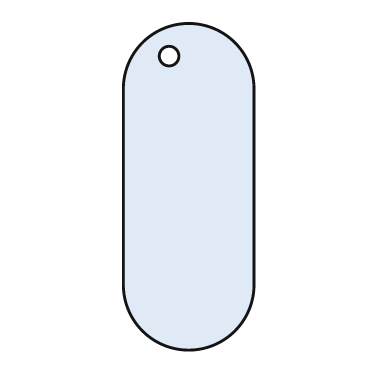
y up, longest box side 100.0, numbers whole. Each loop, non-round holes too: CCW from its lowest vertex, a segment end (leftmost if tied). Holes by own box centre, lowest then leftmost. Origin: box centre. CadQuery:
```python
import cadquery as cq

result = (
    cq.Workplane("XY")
    .moveTo(-20.0, -30.0)
    .threePointArc((0.0, -50.0), (20.0, -30.0))
    .lineTo(20.0, 30.0)
    .threePointArc((0.0, 50.0), (-20.0, 30.0))
    .close()
    .moveTo(-6.0, 40.0)
    .circle(3.0)
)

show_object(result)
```